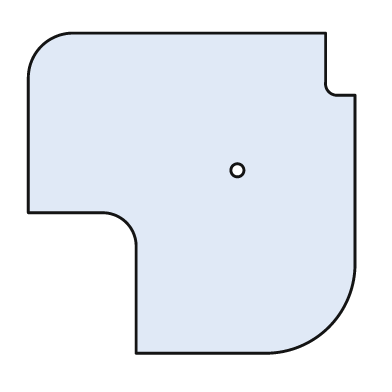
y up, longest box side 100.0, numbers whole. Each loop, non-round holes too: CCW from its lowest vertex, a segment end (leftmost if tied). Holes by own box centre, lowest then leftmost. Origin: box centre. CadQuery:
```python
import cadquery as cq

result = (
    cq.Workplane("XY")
    .moveTo(-17.0, -49.0)
    .lineTo(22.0, -49.0)
    .threePointArc((42.0, -41.0), (50.0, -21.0))
    .lineTo(50.0, 30.0)
    .lineTo(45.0, 30.0)
    .threePointArc((42.0, 31.0), (41.0, 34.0))
    .lineTo(41.0, 49.0)
    .lineTo(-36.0, 49.0)
    .threePointArc((-46.0, 45.0), (-50.0, 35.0))
    .lineTo(-50.0, -6.0)
    .lineTo(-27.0, -6.0)
    .threePointArc((-20.0, -9.0), (-17.0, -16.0))
    .close()
    .moveTo(14.0, 7.0)
    .circle(2.0)
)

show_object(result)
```